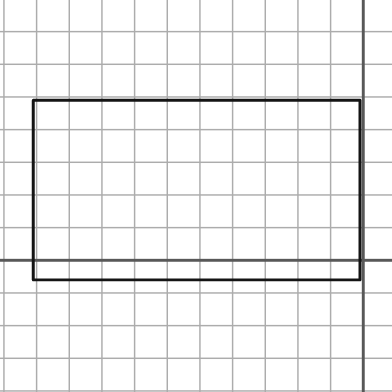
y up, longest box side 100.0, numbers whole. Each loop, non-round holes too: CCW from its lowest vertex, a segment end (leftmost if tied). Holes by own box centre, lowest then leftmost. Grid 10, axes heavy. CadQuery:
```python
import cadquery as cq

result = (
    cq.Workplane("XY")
    .moveTo(-101.0, -6.0)
    .lineTo(-1.0, -6.0)
    .lineTo(-1.0, 49.0)
    .lineTo(-101.0, 49.0)
    .close()
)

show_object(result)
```